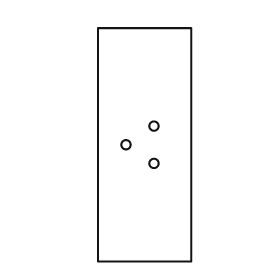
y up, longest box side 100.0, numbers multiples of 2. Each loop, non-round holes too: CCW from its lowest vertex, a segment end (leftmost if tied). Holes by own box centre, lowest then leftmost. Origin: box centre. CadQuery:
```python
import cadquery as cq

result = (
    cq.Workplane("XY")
    .moveTo(-20.0, -50.0)
    .lineTo(20.0, -50.0)
    .lineTo(20.0, 50.0)
    .lineTo(-20.0, 50.0)
    .close()
    .moveTo(4.0, -8.0)
    .circle(2.0)
    .moveTo(-8.0, 0.0)
    .circle(2.0)
    .moveTo(4.0, 8.0)
    .circle(2.0)
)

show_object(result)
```